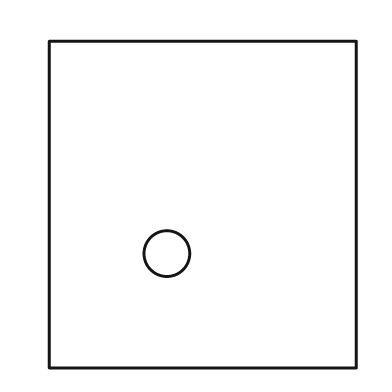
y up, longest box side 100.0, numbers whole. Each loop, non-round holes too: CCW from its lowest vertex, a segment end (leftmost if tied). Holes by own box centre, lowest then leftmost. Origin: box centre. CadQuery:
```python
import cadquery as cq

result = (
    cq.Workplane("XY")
    .moveTo(-47.0, -50.0)
    .lineTo(47.0, -50.0)
    .lineTo(47.0, 50.0)
    .lineTo(-47.0, 50.0)
    .close()
    .moveTo(-11.0, -15.0)
    .circle(7.0)
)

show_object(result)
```